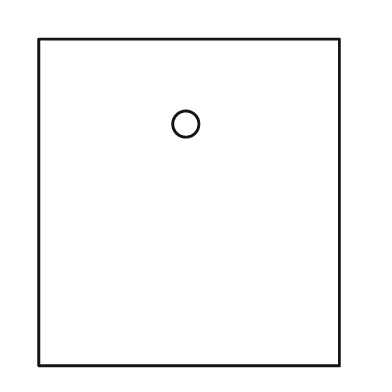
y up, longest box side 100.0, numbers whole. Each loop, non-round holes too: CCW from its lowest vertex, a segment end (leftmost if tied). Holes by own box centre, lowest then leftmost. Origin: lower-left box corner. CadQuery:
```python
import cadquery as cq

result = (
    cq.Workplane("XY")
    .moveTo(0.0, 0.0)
    .lineTo(92.0, 0.0)
    .lineTo(92.0, 100.0)
    .lineTo(0.0, 100.0)
    .close()
    .moveTo(45.0, 74.0)
    .circle(4.0)
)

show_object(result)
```